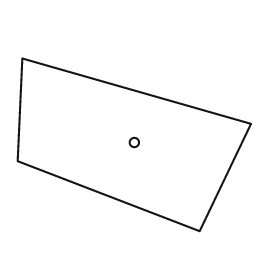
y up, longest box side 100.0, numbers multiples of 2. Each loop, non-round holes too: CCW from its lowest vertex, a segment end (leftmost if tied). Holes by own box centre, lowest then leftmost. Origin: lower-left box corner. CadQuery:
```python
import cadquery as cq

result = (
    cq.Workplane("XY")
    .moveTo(78.0, 0.0)
    .lineTo(100.0, 46.0)
    .lineTo(2.0, 74.0)
    .lineTo(0.0, 30.0)
    .close()
    .moveTo(50.0, 38.0)
    .circle(2.0)
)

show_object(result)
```